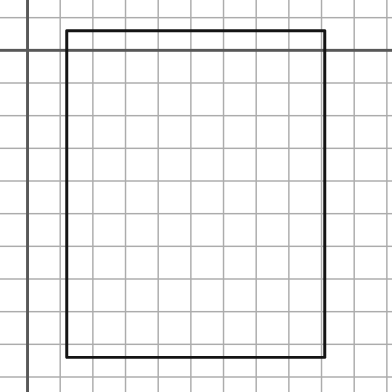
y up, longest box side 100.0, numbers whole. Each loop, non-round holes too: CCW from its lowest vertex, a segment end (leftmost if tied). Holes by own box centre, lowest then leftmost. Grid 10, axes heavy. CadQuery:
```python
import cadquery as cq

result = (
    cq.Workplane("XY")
    .moveTo(12.0, -94.0)
    .lineTo(91.0, -94.0)
    .lineTo(91.0, 6.0)
    .lineTo(12.0, 6.0)
    .close()
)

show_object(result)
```